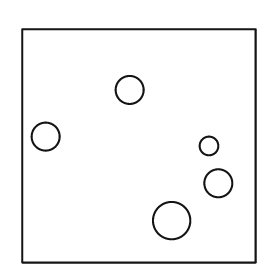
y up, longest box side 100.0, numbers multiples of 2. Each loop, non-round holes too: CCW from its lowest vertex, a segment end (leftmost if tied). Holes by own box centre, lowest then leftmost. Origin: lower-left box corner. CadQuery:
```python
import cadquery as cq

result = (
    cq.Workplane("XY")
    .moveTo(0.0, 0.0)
    .lineTo(100.0, 0.0)
    .lineTo(100.0, 100.0)
    .lineTo(0.0, 100.0)
    .close()
    .moveTo(64.0, 18.0)
    .circle(8.0)
    .moveTo(84.0, 34.0)
    .circle(6.0)
    .moveTo(80.0, 50.0)
    .circle(4.0)
    .moveTo(10.0, 54.0)
    .circle(6.0)
    .moveTo(46.0, 74.0)
    .circle(6.0)
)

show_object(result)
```